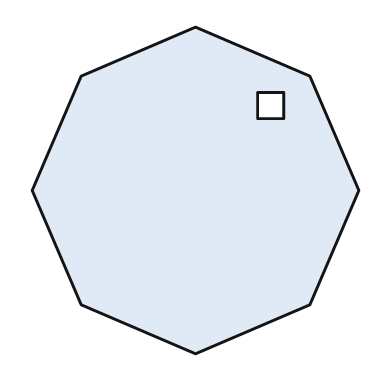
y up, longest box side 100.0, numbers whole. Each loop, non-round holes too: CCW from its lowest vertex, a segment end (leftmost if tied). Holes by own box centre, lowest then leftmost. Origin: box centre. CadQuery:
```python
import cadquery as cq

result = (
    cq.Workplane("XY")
    .moveTo(0.0, -50.0)
    .lineTo(35.0, -35.0)
    .lineTo(50.0, 0.0)
    .lineTo(35.0, 35.0)
    .lineTo(0.0, 50.0)
    .lineTo(-35.0, 35.0)
    .lineTo(-50.0, 0.0)
    .lineTo(-35.0, -35.0)
    .close()
    .moveTo(19.0, 22.0)
    .lineTo(27.0, 22.0)
    .lineTo(27.0, 30.0)
    .lineTo(19.0, 30.0)
    .close()
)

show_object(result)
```